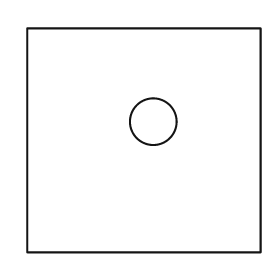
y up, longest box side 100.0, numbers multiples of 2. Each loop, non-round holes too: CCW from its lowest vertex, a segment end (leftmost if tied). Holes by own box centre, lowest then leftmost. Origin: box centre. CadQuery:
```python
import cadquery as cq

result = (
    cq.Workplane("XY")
    .moveTo(-50.0, -48.0)
    .lineTo(50.0, -48.0)
    .lineTo(50.0, 48.0)
    .lineTo(-50.0, 48.0)
    .close()
    .moveTo(4.0, 8.0)
    .circle(10.0)
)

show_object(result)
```